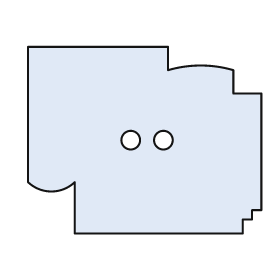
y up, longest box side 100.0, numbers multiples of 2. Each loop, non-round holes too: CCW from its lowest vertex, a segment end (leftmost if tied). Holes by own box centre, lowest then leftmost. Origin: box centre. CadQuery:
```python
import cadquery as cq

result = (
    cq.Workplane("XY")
    .moveTo(-30.0, -40.0)
    .lineTo(42.0, -40.0)
    .lineTo(42.0, -34.0)
    .lineTo(46.0, -34.0)
    .lineTo(46.0, -30.0)
    .lineTo(50.0, -30.0)
    .lineTo(50.0, 20.0)
    .lineTo(38.0, 20.0)
    .lineTo(38.0, 30.0)
    .threePointArc((24.0, 32.0), (10.0, 30.0))
    .lineTo(10.0, 40.0)
    .lineTo(-50.0, 40.0)
    .lineTo(-50.0, -18.0)
    .threePointArc((-40.0, -22.0), (-30.0, -18.0))
    .close()
    .moveTo(-6.0, 0.0)
    .circle(4.0)
    .moveTo(8.0, 0.0)
    .circle(4.0)
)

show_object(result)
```